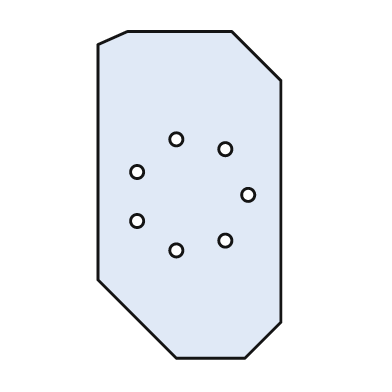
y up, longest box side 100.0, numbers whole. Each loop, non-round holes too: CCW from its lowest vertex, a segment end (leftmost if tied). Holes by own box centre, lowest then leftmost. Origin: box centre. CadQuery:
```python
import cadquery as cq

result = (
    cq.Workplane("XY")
    .moveTo(-4.0, -50.0)
    .lineTo(17.0, -50.0)
    .lineTo(28.0, -39.0)
    .lineTo(28.0, 35.0)
    .lineTo(13.0, 50.0)
    .lineTo(-19.0, 50.0)
    .lineTo(-28.0, 46.0)
    .lineTo(-28.0, -26.0)
    .close()
    .moveTo(-4.0, -17.0)
    .circle(2.0)
    .moveTo(11.0, -14.0)
    .circle(2.0)
    .moveTo(-16.0, -8.0)
    .circle(2.0)
    .moveTo(18.0, 0.0)
    .circle(2.0)
    .moveTo(-16.0, 7.0)
    .circle(2.0)
    .moveTo(11.0, 14.0)
    .circle(2.0)
    .moveTo(-4.0, 17.0)
    .circle(2.0)
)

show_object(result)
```